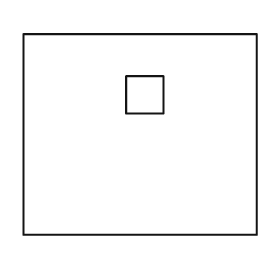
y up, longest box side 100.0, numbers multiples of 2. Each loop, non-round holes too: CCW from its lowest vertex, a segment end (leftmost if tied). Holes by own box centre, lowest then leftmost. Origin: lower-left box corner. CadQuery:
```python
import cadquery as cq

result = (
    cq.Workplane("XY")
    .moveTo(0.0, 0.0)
    .lineTo(100.0, 0.0)
    .lineTo(100.0, 86.0)
    .lineTo(0.0, 86.0)
    .close()
    .moveTo(44.0, 52.0)
    .lineTo(60.0, 52.0)
    .lineTo(60.0, 68.0)
    .lineTo(44.0, 68.0)
    .close()
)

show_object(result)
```